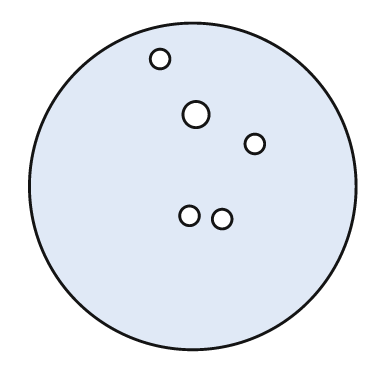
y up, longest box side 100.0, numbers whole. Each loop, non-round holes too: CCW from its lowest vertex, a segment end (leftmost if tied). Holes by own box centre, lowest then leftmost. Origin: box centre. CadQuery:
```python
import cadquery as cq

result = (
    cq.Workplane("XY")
    .moveTo(0.0, 0.0)
    .circle(50.0)
    .moveTo(9.0, -10.0)
    .circle(3.0)
    .moveTo(-1.0, -9.0)
    .circle(3.0)
    .moveTo(19.0, 13.0)
    .circle(3.0)
    .moveTo(1.0, 22.0)
    .circle(4.0)
    .moveTo(-10.0, 39.0)
    .circle(3.0)
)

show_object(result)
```